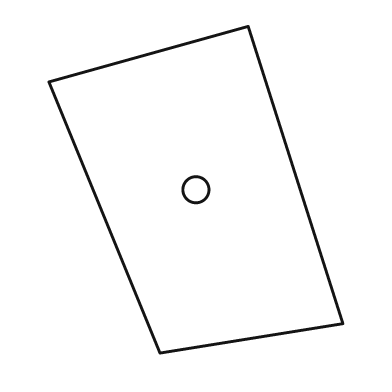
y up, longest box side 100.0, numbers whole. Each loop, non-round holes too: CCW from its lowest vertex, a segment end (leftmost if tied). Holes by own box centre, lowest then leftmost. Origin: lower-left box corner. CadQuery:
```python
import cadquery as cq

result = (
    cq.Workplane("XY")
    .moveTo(34.0, 0.0)
    .lineTo(90.0, 9.0)
    .lineTo(61.0, 100.0)
    .lineTo(0.0, 83.0)
    .close()
    .moveTo(45.0, 50.0)
    .circle(4.0)
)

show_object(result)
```